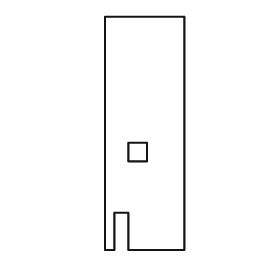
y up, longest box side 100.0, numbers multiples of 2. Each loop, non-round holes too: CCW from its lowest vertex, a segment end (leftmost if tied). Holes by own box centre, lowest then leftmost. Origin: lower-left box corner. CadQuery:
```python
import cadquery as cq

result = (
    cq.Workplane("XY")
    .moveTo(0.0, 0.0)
    .lineTo(4.0, 0.0)
    .lineTo(4.0, 16.0)
    .lineTo(10.0, 16.0)
    .lineTo(10.0, 0.0)
    .lineTo(34.0, 0.0)
    .lineTo(34.0, 100.0)
    .lineTo(0.0, 100.0)
    .close()
    .moveTo(10.0, 38.0)
    .lineTo(18.0, 38.0)
    .lineTo(18.0, 46.0)
    .lineTo(10.0, 46.0)
    .close()
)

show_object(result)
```